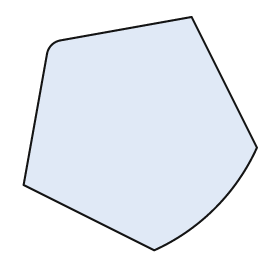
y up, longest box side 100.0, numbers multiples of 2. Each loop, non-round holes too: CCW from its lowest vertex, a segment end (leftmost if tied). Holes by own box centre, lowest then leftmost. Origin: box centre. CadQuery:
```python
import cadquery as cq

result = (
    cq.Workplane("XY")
    .moveTo(6.0, -50.0)
    .threePointArc((32.0, -32.0), (50.0, -6.0))
    .lineTo(22.0, 50.0)
    .lineTo(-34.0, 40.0)
    .threePointArc((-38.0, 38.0), (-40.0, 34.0))
    .lineTo(-50.0, -22.0)
    .close()
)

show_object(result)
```